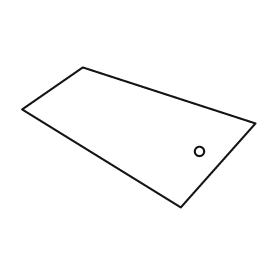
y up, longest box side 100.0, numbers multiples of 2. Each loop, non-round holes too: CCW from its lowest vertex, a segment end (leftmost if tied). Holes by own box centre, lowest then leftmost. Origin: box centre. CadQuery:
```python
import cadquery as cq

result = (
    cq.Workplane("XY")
    .moveTo(18.0, -30.0)
    .lineTo(50.0, 6.0)
    .lineTo(-24.0, 30.0)
    .lineTo(-50.0, 12.0)
    .close()
    .moveTo(26.0, -6.0)
    .circle(2.0)
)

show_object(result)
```